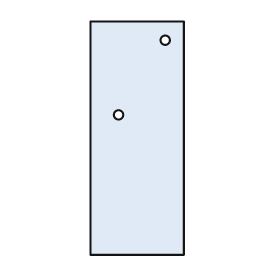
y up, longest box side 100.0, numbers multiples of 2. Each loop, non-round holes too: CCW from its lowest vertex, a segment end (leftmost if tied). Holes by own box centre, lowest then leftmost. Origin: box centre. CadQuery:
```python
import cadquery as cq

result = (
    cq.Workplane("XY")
    .moveTo(-20.0, -50.0)
    .lineTo(20.0, -50.0)
    .lineTo(20.0, 50.0)
    .lineTo(-20.0, 50.0)
    .close()
    .moveTo(-8.0, 10.0)
    .circle(2.0)
    .moveTo(12.0, 42.0)
    .circle(2.0)
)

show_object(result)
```